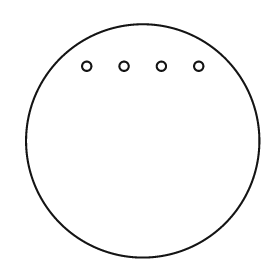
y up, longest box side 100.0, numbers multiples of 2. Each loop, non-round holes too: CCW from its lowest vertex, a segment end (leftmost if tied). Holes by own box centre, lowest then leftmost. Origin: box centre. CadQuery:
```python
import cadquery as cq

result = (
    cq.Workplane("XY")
    .moveTo(0.0, 0.0)
    .circle(50.0)
    .moveTo(-24.0, 32.0)
    .circle(2.0)
    .moveTo(-8.0, 32.0)
    .circle(2.0)
    .moveTo(8.0, 32.0)
    .circle(2.0)
    .moveTo(24.0, 32.0)
    .circle(2.0)
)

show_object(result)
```